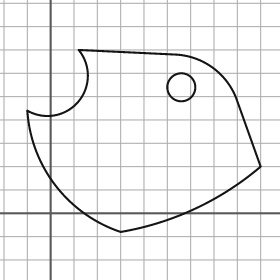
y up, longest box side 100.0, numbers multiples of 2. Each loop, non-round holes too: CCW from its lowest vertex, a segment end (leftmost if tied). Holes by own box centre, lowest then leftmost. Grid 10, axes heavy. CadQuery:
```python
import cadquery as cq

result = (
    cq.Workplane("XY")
    .moveTo(30.0, -8.0)
    .threePointArc((62.0, 2.0), (90.0, 20.0))
    .lineTo(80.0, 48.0)
    .threePointArc((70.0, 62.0), (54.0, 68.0))
    .lineTo(12.0, 70.0)
    .threePointArc((12.0, 48.0), (-10.0, 44.0))
    .threePointArc((2.0, 12.0), (30.0, -8.0))
    .close()
    .moveTo(56.0, 54.0)
    .circle(6.0)
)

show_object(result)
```